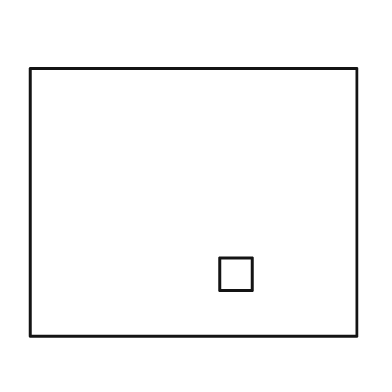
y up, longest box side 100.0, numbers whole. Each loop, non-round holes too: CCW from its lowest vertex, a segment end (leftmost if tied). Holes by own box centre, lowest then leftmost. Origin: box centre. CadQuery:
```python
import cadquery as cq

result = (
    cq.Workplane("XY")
    .moveTo(-50.0, -41.0)
    .lineTo(50.0, -41.0)
    .lineTo(50.0, 41.0)
    .lineTo(-50.0, 41.0)
    .close()
    .moveTo(8.0, -27.0)
    .lineTo(18.0, -27.0)
    .lineTo(18.0, -17.0)
    .lineTo(8.0, -17.0)
    .close()
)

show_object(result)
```